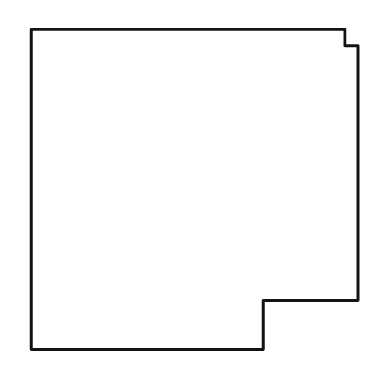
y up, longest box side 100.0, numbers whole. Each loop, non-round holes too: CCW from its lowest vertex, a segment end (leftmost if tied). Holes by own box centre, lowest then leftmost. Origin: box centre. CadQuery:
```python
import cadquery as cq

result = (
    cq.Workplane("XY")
    .moveTo(-50.0, -49.0)
    .lineTo(21.0, -49.0)
    .lineTo(21.0, -34.0)
    .lineTo(50.0, -34.0)
    .lineTo(50.0, 44.0)
    .lineTo(46.0, 44.0)
    .lineTo(46.0, 49.0)
    .lineTo(-50.0, 49.0)
    .close()
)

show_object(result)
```